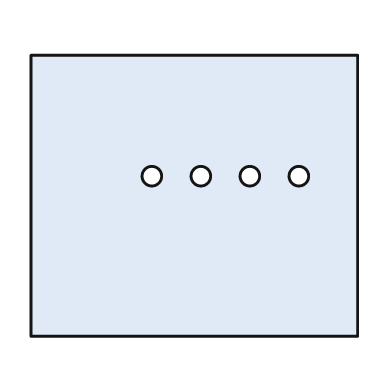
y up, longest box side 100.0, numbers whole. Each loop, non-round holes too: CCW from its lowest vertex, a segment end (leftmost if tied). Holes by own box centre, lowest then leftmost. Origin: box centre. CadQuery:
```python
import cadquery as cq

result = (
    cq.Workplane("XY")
    .moveTo(-50.0, -43.0)
    .lineTo(50.0, -43.0)
    .lineTo(50.0, 43.0)
    .lineTo(-50.0, 43.0)
    .close()
    .moveTo(-13.0, 6.0)
    .circle(3.0)
    .moveTo(2.0, 6.0)
    .circle(3.0)
    .moveTo(17.0, 6.0)
    .circle(3.0)
    .moveTo(32.0, 6.0)
    .circle(3.0)
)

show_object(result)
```